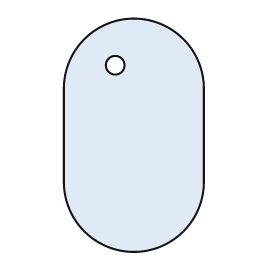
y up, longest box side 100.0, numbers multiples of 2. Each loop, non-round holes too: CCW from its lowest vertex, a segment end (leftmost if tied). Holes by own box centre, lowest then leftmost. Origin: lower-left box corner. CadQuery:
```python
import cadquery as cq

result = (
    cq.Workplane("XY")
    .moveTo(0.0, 30.0)
    .threePointArc((30.0, 0.0), (60.0, 30.0))
    .lineTo(60.0, 70.0)
    .threePointArc((30.0, 100.0), (0.0, 70.0))
    .close()
    .moveTo(22.0, 80.0)
    .circle(4.0)
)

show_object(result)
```